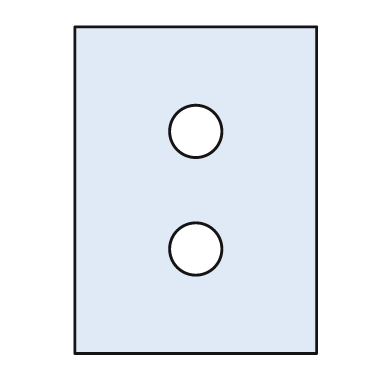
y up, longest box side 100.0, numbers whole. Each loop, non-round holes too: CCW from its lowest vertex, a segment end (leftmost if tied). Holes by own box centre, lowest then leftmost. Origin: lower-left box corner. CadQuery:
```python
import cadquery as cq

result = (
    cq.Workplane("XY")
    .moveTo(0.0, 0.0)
    .lineTo(74.0, 0.0)
    .lineTo(74.0, 100.0)
    .lineTo(0.0, 100.0)
    .close()
    .moveTo(37.0, 32.0)
    .circle(8.0)
    .moveTo(37.0, 68.0)
    .circle(8.0)
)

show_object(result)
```